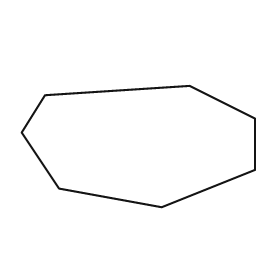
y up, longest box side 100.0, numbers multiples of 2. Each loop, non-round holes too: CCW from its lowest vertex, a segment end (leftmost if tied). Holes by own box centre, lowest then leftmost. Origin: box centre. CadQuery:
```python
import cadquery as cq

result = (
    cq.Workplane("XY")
    .moveTo(10.0, -26.0)
    .lineTo(50.0, -10.0)
    .lineTo(50.0, 12.0)
    .lineTo(22.0, 26.0)
    .lineTo(-40.0, 22.0)
    .lineTo(-50.0, 6.0)
    .lineTo(-34.0, -18.0)
    .close()
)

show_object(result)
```